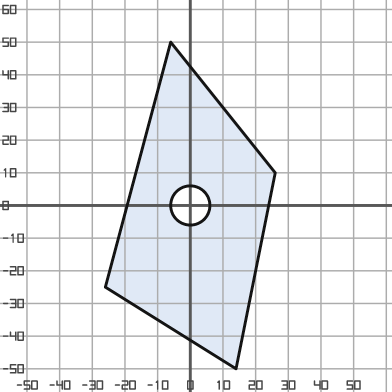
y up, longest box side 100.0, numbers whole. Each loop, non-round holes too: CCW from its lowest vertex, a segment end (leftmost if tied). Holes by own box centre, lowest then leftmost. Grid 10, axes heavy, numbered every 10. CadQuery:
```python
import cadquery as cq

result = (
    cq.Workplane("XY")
    .moveTo(14.0, -50.0)
    .lineTo(26.0, 10.0)
    .lineTo(-6.0, 50.0)
    .lineTo(-26.0, -25.0)
    .close()
    .moveTo(0.0, 0.0)
    .circle(6.0)
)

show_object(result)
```